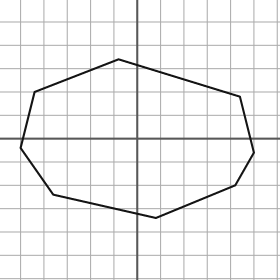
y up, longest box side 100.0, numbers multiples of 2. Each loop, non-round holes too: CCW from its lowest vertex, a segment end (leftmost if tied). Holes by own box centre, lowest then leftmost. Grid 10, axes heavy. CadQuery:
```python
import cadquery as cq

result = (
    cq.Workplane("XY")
    .moveTo(8.0, -34.0)
    .lineTo(42.0, -20.0)
    .lineTo(50.0, -6.0)
    .lineTo(44.0, 18.0)
    .lineTo(-8.0, 34.0)
    .lineTo(-44.0, 20.0)
    .lineTo(-50.0, -4.0)
    .lineTo(-36.0, -24.0)
    .close()
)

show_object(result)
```